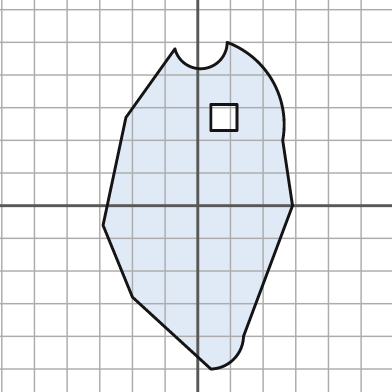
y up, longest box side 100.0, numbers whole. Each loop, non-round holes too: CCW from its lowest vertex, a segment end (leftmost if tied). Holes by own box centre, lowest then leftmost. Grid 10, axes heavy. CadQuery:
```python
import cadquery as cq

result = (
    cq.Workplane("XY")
    .moveTo(4.0, -50.0)
    .threePointArc((11.0, -47.0), (14.0, -40.0))
    .lineTo(29.0, 0.0)
    .lineTo(26.0, 20.0)
    .threePointArc((23.0, 38.0), (9.0, 50.0))
    .threePointArc((2.0, 42.0), (-7.0, 48.0))
    .lineTo(-22.0, 27.0)
    .lineTo(-29.0, -6.0)
    .lineTo(-20.0, -28.0)
    .close()
    .moveTo(4.0, 23.0)
    .lineTo(12.0, 23.0)
    .lineTo(12.0, 31.0)
    .lineTo(4.0, 31.0)
    .close()
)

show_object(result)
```